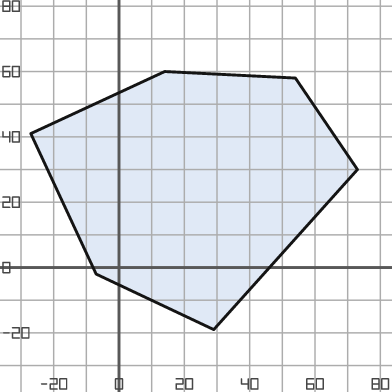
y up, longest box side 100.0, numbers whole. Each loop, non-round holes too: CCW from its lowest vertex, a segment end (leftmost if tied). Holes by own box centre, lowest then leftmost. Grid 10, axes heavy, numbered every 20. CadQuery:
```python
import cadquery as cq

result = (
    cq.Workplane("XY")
    .moveTo(29.0, -19.0)
    .lineTo(73.0, 30.0)
    .lineTo(54.0, 58.0)
    .lineTo(14.0, 60.0)
    .lineTo(-27.0, 41.0)
    .lineTo(-7.0, -2.0)
    .close()
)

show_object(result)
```